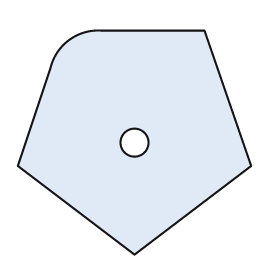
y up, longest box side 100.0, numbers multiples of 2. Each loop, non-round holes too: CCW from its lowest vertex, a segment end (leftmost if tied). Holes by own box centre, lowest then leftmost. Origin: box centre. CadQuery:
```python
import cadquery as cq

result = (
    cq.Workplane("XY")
    .moveTo(0.0, -48.0)
    .lineTo(50.0, -10.0)
    .lineTo(30.0, 48.0)
    .lineTo(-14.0, 48.0)
    .threePointArc((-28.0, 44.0), (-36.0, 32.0))
    .lineTo(-50.0, -10.0)
    .close()
    .moveTo(0.0, 0.0)
    .circle(6.0)
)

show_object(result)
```